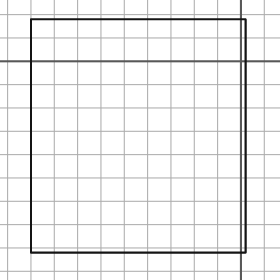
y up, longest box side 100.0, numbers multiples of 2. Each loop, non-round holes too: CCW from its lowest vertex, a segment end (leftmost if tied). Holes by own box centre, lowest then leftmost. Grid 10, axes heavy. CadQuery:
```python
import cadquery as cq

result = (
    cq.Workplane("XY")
    .moveTo(-90.0, -82.0)
    .lineTo(2.0, -82.0)
    .lineTo(2.0, 18.0)
    .lineTo(-90.0, 18.0)
    .close()
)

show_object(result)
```